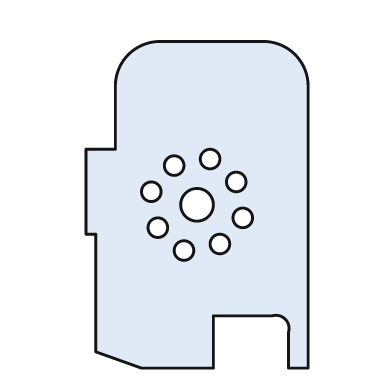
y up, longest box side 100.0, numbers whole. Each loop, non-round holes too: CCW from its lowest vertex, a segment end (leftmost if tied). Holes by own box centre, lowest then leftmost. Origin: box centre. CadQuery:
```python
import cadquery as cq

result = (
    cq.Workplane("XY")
    .moveTo(-17.0, -50.0)
    .lineTo(5.0, -50.0)
    .lineTo(5.0, -34.0)
    .lineTo(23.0, -34.0)
    .threePointArc((27.0, -35.0), (28.0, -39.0))
    .lineTo(28.0, -50.0)
    .lineTo(34.0, -50.0)
    .lineTo(34.0, 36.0)
    .threePointArc((30.0, 46.0), (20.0, 50.0))
    .lineTo(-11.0, 50.0)
    .threePointArc((-21.0, 46.0), (-25.0, 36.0))
    .lineTo(-25.0, 17.0)
    .lineTo(-34.0, 17.0)
    .lineTo(-34.0, -9.0)
    .lineTo(-31.0, -9.0)
    .lineTo(-31.0, -45.0)
    .close()
    .moveTo(-4.0, -14.0)
    .circle(3.0)
    .moveTo(7.0, -12.0)
    .circle(3.0)
    .moveTo(-12.0, -7.0)
    .circle(3.0)
    .moveTo(14.0, -4.0)
    .circle(3.0)
    .moveTo(0.0, 0.0)
    .circle(5.0)
    .moveTo(-14.0, 4.0)
    .circle(3.0)
    .moveTo(12.0, 7.0)
    .circle(3.0)
    .moveTo(-7.0, 12.0)
    .circle(3.0)
    .moveTo(4.0, 14.0)
    .circle(3.0)
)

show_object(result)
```